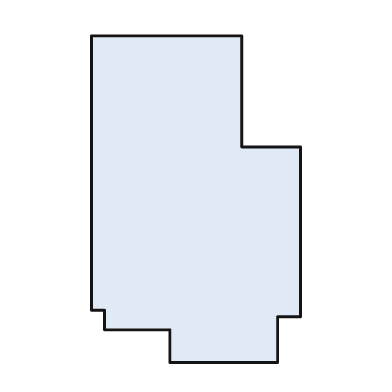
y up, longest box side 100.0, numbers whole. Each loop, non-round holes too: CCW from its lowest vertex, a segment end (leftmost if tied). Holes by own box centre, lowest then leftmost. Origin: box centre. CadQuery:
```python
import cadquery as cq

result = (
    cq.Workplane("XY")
    .moveTo(-8.0, -50.0)
    .lineTo(25.0, -50.0)
    .lineTo(25.0, -36.0)
    .lineTo(32.0, -36.0)
    .lineTo(32.0, 16.0)
    .lineTo(14.0, 16.0)
    .lineTo(14.0, 50.0)
    .lineTo(-32.0, 50.0)
    .lineTo(-32.0, -34.0)
    .lineTo(-28.0, -34.0)
    .lineTo(-28.0, -40.0)
    .lineTo(-8.0, -40.0)
    .close()
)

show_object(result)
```